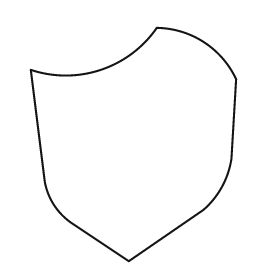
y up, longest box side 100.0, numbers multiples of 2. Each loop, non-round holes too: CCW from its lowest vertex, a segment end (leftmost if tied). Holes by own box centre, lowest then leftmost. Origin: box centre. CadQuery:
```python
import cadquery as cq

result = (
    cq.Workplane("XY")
    .moveTo(-2.0, -50.0)
    .lineTo(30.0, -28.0)
    .threePointArc((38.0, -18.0), (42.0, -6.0))
    .lineTo(44.0, 28.0)
    .threePointArc((30.0, 44.0), (10.0, 50.0))
    .threePointArc((-14.0, 32.0), (-44.0, 32.0))
    .lineTo(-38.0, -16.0)
    .threePointArc((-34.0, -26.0), (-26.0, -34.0))
    .close()
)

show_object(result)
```